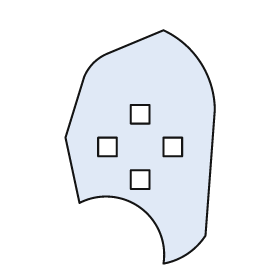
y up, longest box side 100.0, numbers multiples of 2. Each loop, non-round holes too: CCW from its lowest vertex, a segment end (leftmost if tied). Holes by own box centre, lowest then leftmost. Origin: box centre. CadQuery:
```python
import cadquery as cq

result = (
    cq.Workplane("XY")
    .moveTo(10.0, -50.0)
    .threePointArc((20.0, -46.0), (28.0, -38.0))
    .lineTo(32.0, 16.0)
    .threePointArc((26.0, 36.0), (10.0, 50.0))
    .lineTo(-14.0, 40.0)
    .threePointArc((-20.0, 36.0), (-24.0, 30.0))
    .lineTo(-32.0, 4.0)
    .lineTo(-26.0, -24.0)
    .threePointArc((0.0, -26.0), (10.0, -50.0))
    .close()
    .moveTo(-4.0, -18.0)
    .lineTo(4.0, -18.0)
    .lineTo(4.0, -10.0)
    .lineTo(-4.0, -10.0)
    .close()
    .moveTo(-18.0, -4.0)
    .lineTo(-10.0, -4.0)
    .lineTo(-10.0, 4.0)
    .lineTo(-18.0, 4.0)
    .close()
    .moveTo(10.0, -4.0)
    .lineTo(18.0, -4.0)
    .lineTo(18.0, 4.0)
    .lineTo(10.0, 4.0)
    .close()
    .moveTo(-4.0, 10.0)
    .lineTo(4.0, 10.0)
    .lineTo(4.0, 18.0)
    .lineTo(-4.0, 18.0)
    .close()
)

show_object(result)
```